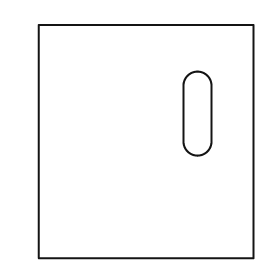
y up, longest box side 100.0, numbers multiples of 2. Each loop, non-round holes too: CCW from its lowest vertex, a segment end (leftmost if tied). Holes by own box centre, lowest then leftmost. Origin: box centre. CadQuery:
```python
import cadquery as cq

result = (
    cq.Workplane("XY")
    .moveTo(-46.0, -50.0)
    .lineTo(46.0, -50.0)
    .lineTo(46.0, 50.0)
    .lineTo(-46.0, 50.0)
    .close()
    .moveTo(16.0, 0.0)
    .threePointArc((22.0, -6.0), (28.0, 0.0))
    .lineTo(28.0, 24.0)
    .threePointArc((22.0, 30.0), (16.0, 24.0))
    .close()
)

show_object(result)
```